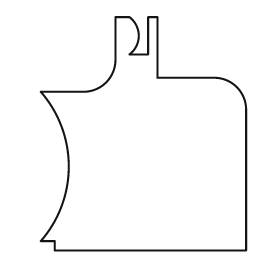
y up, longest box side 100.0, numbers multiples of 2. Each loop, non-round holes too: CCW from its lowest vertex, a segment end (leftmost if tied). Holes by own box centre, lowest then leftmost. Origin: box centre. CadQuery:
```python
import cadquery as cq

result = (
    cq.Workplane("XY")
    .moveTo(-38.0, -50.0)
    .lineTo(44.0, -50.0)
    .lineTo(44.0, 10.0)
    .threePointArc((40.0, 20.0), (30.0, 24.0))
    .lineTo(6.0, 24.0)
    .lineTo(6.0, 50.0)
    .lineTo(2.0, 50.0)
    .lineTo(2.0, 34.0)
    .lineTo(-6.0, 34.0)
    .threePointArc((-2.0, 42.0), (-6.0, 50.0))
    .lineTo(-12.0, 50.0)
    .lineTo(-12.0, 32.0)
    .threePointArc((-16.0, 22.0), (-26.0, 18.0))
    .lineTo(-44.0, 18.0)
    .threePointArc((-32.0, -14.0), (-44.0, -46.0))
    .lineTo(-38.0, -46.0)
    .close()
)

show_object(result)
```